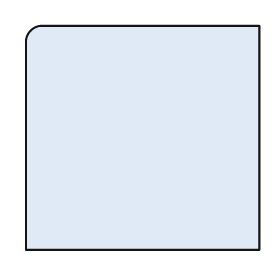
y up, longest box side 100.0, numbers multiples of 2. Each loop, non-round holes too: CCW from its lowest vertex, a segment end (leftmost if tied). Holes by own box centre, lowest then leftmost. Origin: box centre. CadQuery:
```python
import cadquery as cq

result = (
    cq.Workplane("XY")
    .moveTo(-50.0, -48.0)
    .lineTo(50.0, -48.0)
    .lineTo(50.0, 48.0)
    .lineTo(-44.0, 48.0)
    .threePointArc((-48.0, 46.0), (-50.0, 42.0))
    .close()
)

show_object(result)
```